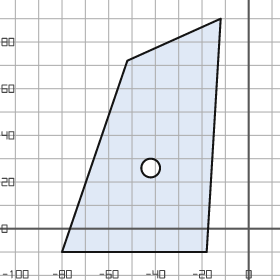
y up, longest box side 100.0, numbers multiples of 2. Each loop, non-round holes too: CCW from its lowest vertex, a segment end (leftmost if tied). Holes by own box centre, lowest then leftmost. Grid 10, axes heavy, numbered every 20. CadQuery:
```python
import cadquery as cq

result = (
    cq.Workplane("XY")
    .moveTo(-80.0, -10.0)
    .lineTo(-18.0, -10.0)
    .lineTo(-12.0, 90.0)
    .lineTo(-52.0, 72.0)
    .close()
    .moveTo(-42.0, 26.0)
    .circle(4.0)
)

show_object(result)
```